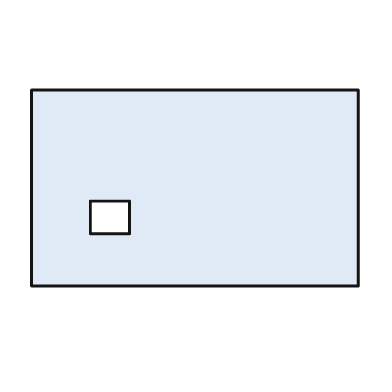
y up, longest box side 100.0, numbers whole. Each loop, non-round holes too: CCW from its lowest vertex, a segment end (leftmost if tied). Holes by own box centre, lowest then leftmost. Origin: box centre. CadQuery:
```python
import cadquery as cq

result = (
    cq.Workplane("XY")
    .moveTo(-50.0, -30.0)
    .lineTo(50.0, -30.0)
    .lineTo(50.0, 30.0)
    .lineTo(-50.0, 30.0)
    .close()
    .moveTo(-32.0, -14.0)
    .lineTo(-20.0, -14.0)
    .lineTo(-20.0, -4.0)
    .lineTo(-32.0, -4.0)
    .close()
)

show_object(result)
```